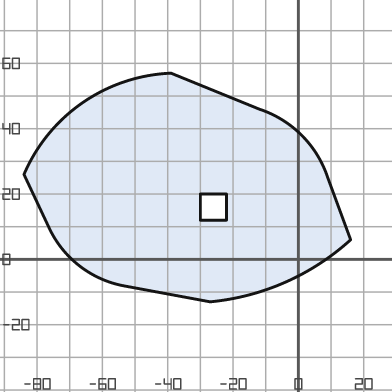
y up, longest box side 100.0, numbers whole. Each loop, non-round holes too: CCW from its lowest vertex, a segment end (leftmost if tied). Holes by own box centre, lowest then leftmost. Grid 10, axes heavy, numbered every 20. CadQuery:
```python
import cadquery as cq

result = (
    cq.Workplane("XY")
    .moveTo(-27.0, -13.0)
    .threePointArc((-4.0, -7.0), (16.0, 6.0))
    .lineTo(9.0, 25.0)
    .threePointArc((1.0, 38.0), (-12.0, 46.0))
    .lineTo(-39.0, 57.0)
    .threePointArc((-66.0, 48.0), (-84.0, 26.0))
    .lineTo(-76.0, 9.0)
    .threePointArc((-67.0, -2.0), (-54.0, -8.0))
    .close()
    .moveTo(-30.0, 12.0)
    .lineTo(-22.0, 12.0)
    .lineTo(-22.0, 20.0)
    .lineTo(-30.0, 20.0)
    .close()
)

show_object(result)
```